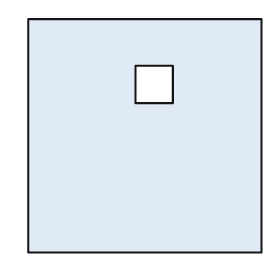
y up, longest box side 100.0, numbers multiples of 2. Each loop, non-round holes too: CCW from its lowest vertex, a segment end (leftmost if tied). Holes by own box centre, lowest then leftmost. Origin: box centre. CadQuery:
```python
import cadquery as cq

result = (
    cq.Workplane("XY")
    .moveTo(-50.0, -50.0)
    .lineTo(50.0, -50.0)
    .lineTo(50.0, 50.0)
    .lineTo(-50.0, 50.0)
    .close()
    .moveTo(-4.0, 14.0)
    .lineTo(12.0, 14.0)
    .lineTo(12.0, 30.0)
    .lineTo(-4.0, 30.0)
    .close()
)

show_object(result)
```